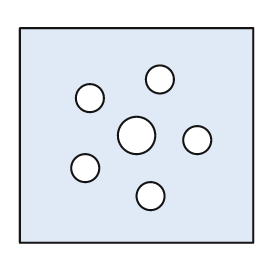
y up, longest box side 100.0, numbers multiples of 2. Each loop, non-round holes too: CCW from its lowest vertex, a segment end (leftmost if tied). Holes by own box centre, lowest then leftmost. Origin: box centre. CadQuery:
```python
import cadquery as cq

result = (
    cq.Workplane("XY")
    .moveTo(-50.0, -46.0)
    .lineTo(50.0, -46.0)
    .lineTo(50.0, 46.0)
    .lineTo(-50.0, 46.0)
    .close()
    .moveTo(6.0, -26.0)
    .circle(6.0)
    .moveTo(-22.0, -14.0)
    .circle(6.0)
    .moveTo(26.0, -2.0)
    .circle(6.0)
    .moveTo(0.0, 0.0)
    .circle(8.0)
    .moveTo(-20.0, 16.0)
    .circle(6.0)
    .moveTo(10.0, 24.0)
    .circle(6.0)
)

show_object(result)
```